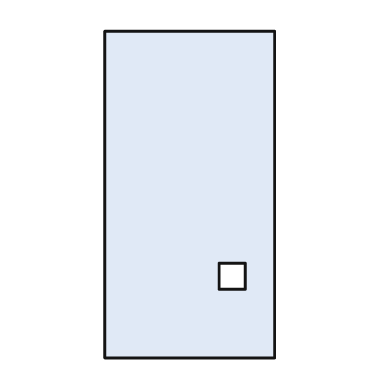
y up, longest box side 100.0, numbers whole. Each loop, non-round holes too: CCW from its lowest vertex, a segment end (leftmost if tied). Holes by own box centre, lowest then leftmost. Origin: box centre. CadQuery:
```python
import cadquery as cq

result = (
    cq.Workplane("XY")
    .moveTo(-26.0, -50.0)
    .lineTo(26.0, -50.0)
    .lineTo(26.0, 50.0)
    .lineTo(-26.0, 50.0)
    .close()
    .moveTo(9.0, -29.0)
    .lineTo(17.0, -29.0)
    .lineTo(17.0, -21.0)
    .lineTo(9.0, -21.0)
    .close()
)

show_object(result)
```